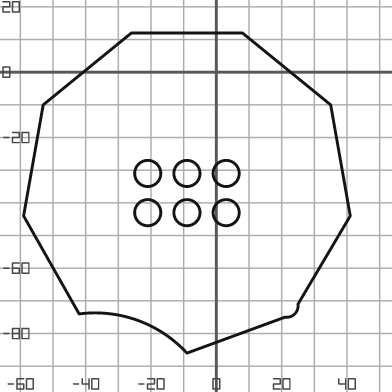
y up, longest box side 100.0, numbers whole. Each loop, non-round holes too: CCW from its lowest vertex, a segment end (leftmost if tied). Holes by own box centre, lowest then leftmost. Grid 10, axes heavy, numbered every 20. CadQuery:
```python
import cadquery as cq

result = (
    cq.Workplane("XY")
    .moveTo(-9.0, -86.0)
    .lineTo(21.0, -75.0)
    .threePointArc((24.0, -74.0), (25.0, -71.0))
    .lineTo(41.0, -44.0)
    .lineTo(35.0, -10.0)
    .lineTo(8.0, 12.0)
    .lineTo(-26.0, 12.0)
    .lineTo(-53.0, -10.0)
    .lineTo(-59.0, -44.0)
    .lineTo(-42.0, -74.0)
    .threePointArc((-24.0, -76.0), (-9.0, -86.0))
    .close()
    .moveTo(-21.0, -43.0)
    .circle(4.0)
    .moveTo(-9.0, -43.0)
    .circle(4.0)
    .moveTo(3.0, -43.0)
    .circle(4.0)
    .moveTo(-21.0, -31.0)
    .circle(4.0)
    .moveTo(-9.0, -31.0)
    .circle(4.0)
    .moveTo(3.0, -31.0)
    .circle(4.0)
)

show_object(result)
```